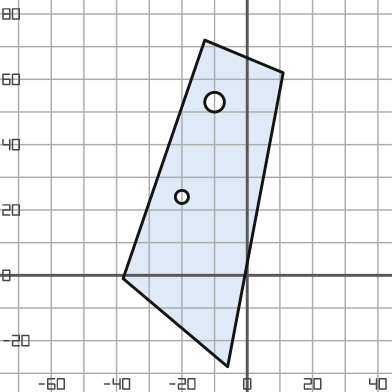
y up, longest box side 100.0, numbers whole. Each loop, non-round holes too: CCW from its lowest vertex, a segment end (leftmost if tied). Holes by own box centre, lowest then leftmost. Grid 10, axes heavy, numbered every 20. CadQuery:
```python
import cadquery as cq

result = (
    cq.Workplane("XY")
    .moveTo(-6.0, -28.0)
    .lineTo(11.0, 62.0)
    .lineTo(-13.0, 72.0)
    .lineTo(-38.0, -1.0)
    .close()
    .moveTo(-20.0, 24.0)
    .circle(2.0)
    .moveTo(-10.0, 53.0)
    .circle(3.0)
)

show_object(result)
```